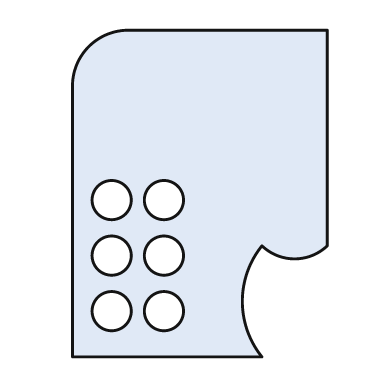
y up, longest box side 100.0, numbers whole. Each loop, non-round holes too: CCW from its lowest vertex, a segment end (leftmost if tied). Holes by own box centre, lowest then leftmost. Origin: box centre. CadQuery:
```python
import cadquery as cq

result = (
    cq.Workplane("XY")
    .moveTo(-39.0, -50.0)
    .lineTo(19.0, -50.0)
    .threePointArc((13.0, -33.0), (19.0, -16.0))
    .threePointArc((29.0, -20.0), (39.0, -16.0))
    .lineTo(39.0, 50.0)
    .lineTo(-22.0, 50.0)
    .threePointArc((-34.0, 45.0), (-39.0, 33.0))
    .close()
    .moveTo(-27.0, -36.0)
    .circle(6.0)
    .moveTo(-11.0, -36.0)
    .circle(6.0)
    .moveTo(-27.0, -19.0)
    .circle(6.0)
    .moveTo(-11.0, -19.0)
    .circle(6.0)
    .moveTo(-27.0, -2.0)
    .circle(6.0)
    .moveTo(-11.0, -2.0)
    .circle(6.0)
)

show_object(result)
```